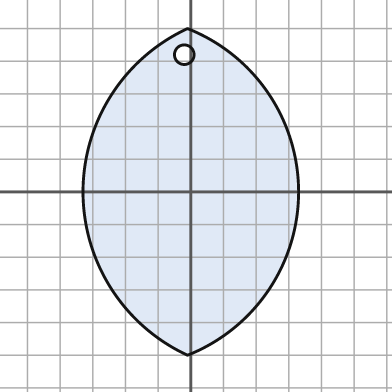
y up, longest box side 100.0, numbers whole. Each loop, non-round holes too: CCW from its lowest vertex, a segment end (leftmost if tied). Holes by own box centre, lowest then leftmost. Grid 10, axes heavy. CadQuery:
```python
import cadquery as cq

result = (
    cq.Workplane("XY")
    .moveTo(-1.0, -50.0)
    .threePointArc((33.0, 0.0), (-1.0, 50.0))
    .threePointArc((-33.0, 0.0), (-1.0, -50.0))
    .close()
    .moveTo(-2.0, 42.0)
    .circle(3.0)
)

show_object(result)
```